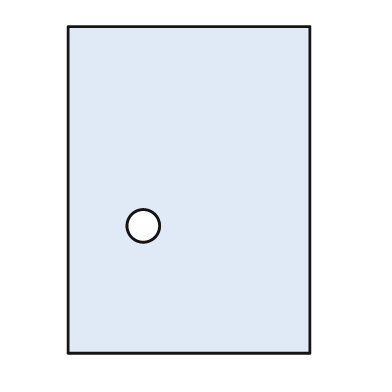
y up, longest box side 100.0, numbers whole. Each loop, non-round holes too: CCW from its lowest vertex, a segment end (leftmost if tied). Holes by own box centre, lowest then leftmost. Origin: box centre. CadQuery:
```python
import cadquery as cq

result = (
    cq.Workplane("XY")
    .moveTo(-37.0, -50.0)
    .lineTo(37.0, -50.0)
    .lineTo(37.0, 50.0)
    .lineTo(-37.0, 50.0)
    .close()
    .moveTo(-14.0, -11.0)
    .circle(5.0)
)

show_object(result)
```